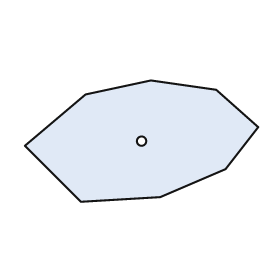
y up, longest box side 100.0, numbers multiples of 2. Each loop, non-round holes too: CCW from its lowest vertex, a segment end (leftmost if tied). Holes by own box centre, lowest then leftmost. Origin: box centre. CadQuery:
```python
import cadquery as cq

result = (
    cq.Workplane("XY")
    .moveTo(-26.0, -26.0)
    .lineTo(8.0, -24.0)
    .lineTo(36.0, -12.0)
    .lineTo(50.0, 6.0)
    .lineTo(32.0, 22.0)
    .lineTo(4.0, 26.0)
    .lineTo(-24.0, 20.0)
    .lineTo(-50.0, -2.0)
    .close()
    .moveTo(0.0, 0.0)
    .circle(2.0)
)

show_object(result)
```